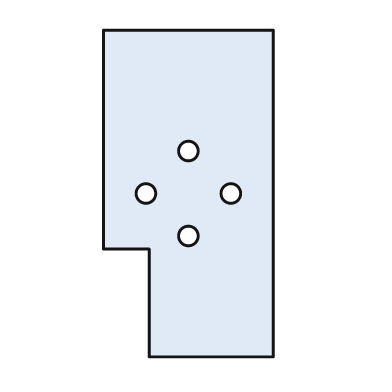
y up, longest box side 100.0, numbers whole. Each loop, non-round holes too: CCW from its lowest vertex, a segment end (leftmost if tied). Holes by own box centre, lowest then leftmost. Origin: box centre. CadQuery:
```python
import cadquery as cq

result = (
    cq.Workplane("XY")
    .moveTo(-12.0, -50.0)
    .lineTo(26.0, -50.0)
    .lineTo(26.0, 50.0)
    .lineTo(-26.0, 50.0)
    .lineTo(-26.0, -17.0)
    .lineTo(-12.0, -17.0)
    .close()
    .moveTo(0.0, -13.0)
    .circle(3.0)
    .moveTo(-13.0, 0.0)
    .circle(3.0)
    .moveTo(13.0, 0.0)
    .circle(3.0)
    .moveTo(0.0, 13.0)
    .circle(3.0)
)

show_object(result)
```